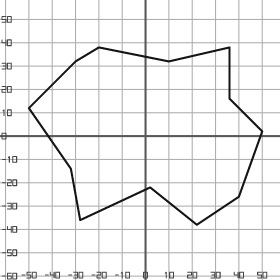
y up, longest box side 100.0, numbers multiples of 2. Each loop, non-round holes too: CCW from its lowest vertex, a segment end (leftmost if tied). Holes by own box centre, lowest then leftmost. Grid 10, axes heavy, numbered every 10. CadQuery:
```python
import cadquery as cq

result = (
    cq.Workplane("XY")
    .moveTo(22.0, -38.0)
    .lineTo(40.0, -26.0)
    .lineTo(50.0, 2.0)
    .lineTo(36.0, 16.0)
    .lineTo(36.0, 38.0)
    .lineTo(10.0, 32.0)
    .lineTo(-20.0, 38.0)
    .lineTo(-30.0, 32.0)
    .lineTo(-50.0, 12.0)
    .lineTo(-32.0, -14.0)
    .lineTo(-28.0, -36.0)
    .lineTo(2.0, -22.0)
    .close()
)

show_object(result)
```